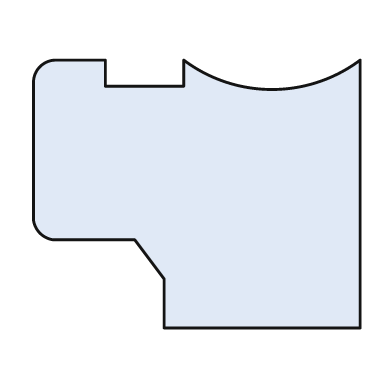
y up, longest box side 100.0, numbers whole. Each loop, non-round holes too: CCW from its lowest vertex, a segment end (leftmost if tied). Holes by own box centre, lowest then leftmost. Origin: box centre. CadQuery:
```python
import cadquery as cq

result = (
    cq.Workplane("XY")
    .moveTo(-10.0, -41.0)
    .lineTo(50.0, -41.0)
    .lineTo(50.0, 41.0)
    .threePointArc((23.0, 32.0), (-4.0, 41.0))
    .lineTo(-4.0, 33.0)
    .lineTo(-28.0, 33.0)
    .lineTo(-28.0, 41.0)
    .lineTo(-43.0, 41.0)
    .threePointArc((-48.0, 39.0), (-50.0, 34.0))
    .lineTo(-50.0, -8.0)
    .threePointArc((-48.0, -12.0), (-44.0, -14.0))
    .lineTo(-19.0, -14.0)
    .lineTo(-10.0, -26.0)
    .close()
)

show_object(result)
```